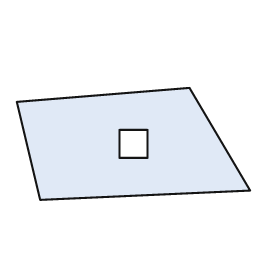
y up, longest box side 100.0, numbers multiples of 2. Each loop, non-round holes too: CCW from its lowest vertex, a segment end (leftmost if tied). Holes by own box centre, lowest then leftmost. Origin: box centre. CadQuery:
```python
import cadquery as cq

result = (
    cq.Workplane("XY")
    .moveTo(-40.0, -24.0)
    .lineTo(50.0, -20.0)
    .lineTo(24.0, 24.0)
    .lineTo(-50.0, 18.0)
    .close()
    .moveTo(-6.0, -6.0)
    .lineTo(6.0, -6.0)
    .lineTo(6.0, 6.0)
    .lineTo(-6.0, 6.0)
    .close()
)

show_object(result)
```